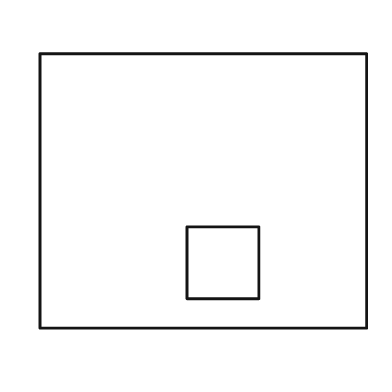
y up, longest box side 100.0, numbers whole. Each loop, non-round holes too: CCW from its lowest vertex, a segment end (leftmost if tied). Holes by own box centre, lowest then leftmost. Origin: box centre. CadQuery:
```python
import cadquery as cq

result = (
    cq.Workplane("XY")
    .moveTo(-50.0, -42.0)
    .lineTo(50.0, -42.0)
    .lineTo(50.0, 42.0)
    .lineTo(-50.0, 42.0)
    .close()
    .moveTo(-5.0, -33.0)
    .lineTo(17.0, -33.0)
    .lineTo(17.0, -11.0)
    .lineTo(-5.0, -11.0)
    .close()
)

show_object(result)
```